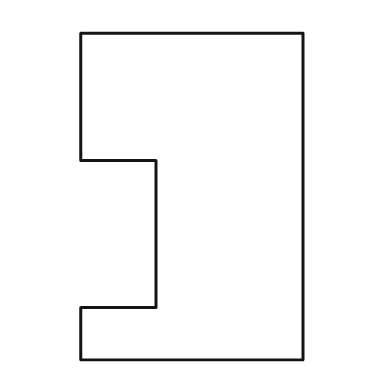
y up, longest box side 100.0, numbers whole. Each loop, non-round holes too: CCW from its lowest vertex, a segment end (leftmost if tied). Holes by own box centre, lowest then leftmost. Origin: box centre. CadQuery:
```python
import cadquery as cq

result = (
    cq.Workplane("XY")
    .moveTo(-34.0, -50.0)
    .lineTo(34.0, -50.0)
    .lineTo(34.0, 50.0)
    .lineTo(-34.0, 50.0)
    .lineTo(-34.0, 11.0)
    .lineTo(-11.0, 11.0)
    .lineTo(-11.0, -34.0)
    .lineTo(-34.0, -34.0)
    .close()
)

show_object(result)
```